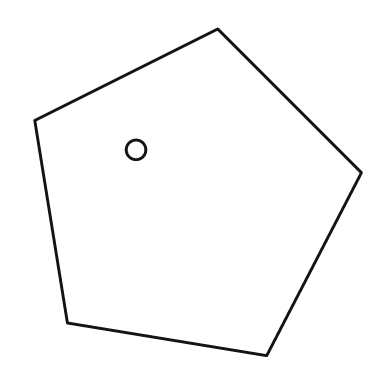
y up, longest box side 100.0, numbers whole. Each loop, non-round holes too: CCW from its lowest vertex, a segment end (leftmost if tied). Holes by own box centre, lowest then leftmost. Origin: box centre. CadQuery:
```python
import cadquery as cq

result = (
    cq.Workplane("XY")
    .moveTo(21.0, -50.0)
    .lineTo(50.0, 6.0)
    .lineTo(6.0, 50.0)
    .lineTo(-50.0, 22.0)
    .lineTo(-40.0, -40.0)
    .close()
    .moveTo(-19.0, 13.0)
    .circle(3.0)
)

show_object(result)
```